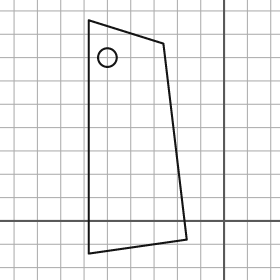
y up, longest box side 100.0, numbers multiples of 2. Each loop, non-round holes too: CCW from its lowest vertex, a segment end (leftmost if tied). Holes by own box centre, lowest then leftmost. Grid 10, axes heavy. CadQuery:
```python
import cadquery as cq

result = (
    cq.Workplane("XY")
    .moveTo(-58.0, -14.0)
    .lineTo(-16.0, -8.0)
    .lineTo(-26.0, 76.0)
    .lineTo(-58.0, 86.0)
    .close()
    .moveTo(-50.0, 70.0)
    .circle(4.0)
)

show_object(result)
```